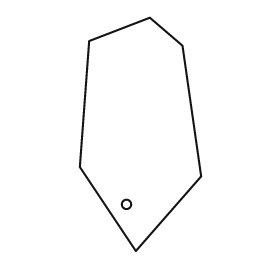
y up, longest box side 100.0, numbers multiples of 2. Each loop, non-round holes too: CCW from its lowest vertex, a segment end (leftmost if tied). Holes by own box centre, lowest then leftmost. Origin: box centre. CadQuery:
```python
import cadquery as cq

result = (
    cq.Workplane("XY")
    .moveTo(-2.0, -50.0)
    .lineTo(26.0, -18.0)
    .lineTo(18.0, 38.0)
    .lineTo(4.0, 50.0)
    .lineTo(-22.0, 40.0)
    .lineTo(-26.0, -14.0)
    .close()
    .moveTo(-6.0, -30.0)
    .circle(2.0)
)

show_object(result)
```